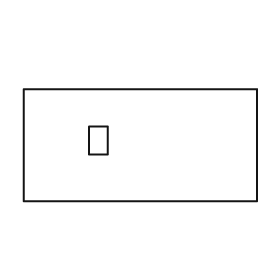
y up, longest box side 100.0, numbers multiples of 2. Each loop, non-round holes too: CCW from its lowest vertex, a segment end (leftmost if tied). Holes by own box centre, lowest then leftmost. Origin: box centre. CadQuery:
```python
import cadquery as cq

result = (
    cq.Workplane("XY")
    .moveTo(-50.0, -24.0)
    .lineTo(50.0, -24.0)
    .lineTo(50.0, 24.0)
    .lineTo(-50.0, 24.0)
    .close()
    .moveTo(-22.0, -4.0)
    .lineTo(-14.0, -4.0)
    .lineTo(-14.0, 8.0)
    .lineTo(-22.0, 8.0)
    .close()
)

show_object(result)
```